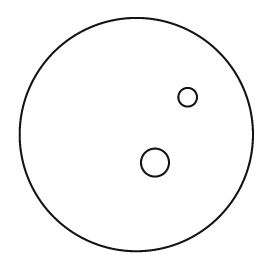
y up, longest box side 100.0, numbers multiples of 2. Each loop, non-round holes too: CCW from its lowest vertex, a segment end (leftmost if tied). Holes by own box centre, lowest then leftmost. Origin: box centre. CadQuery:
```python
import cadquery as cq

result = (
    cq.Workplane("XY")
    .moveTo(0.0, 0.0)
    .circle(50.0)
    .moveTo(8.0, -12.0)
    .circle(6.0)
    .moveTo(22.0, 16.0)
    .circle(4.0)
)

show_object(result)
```